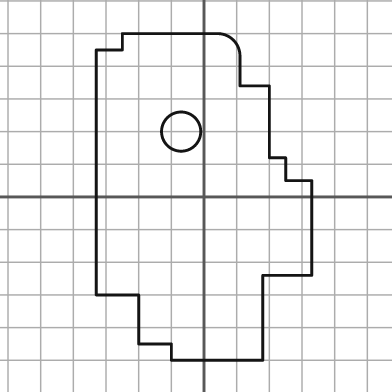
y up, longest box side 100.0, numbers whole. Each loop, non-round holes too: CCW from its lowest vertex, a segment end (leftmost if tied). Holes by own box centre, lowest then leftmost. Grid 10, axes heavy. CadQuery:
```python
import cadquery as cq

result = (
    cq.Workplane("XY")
    .moveTo(-10.0, -50.0)
    .lineTo(18.0, -50.0)
    .lineTo(18.0, -24.0)
    .lineTo(33.0, -24.0)
    .lineTo(33.0, 5.0)
    .lineTo(25.0, 5.0)
    .lineTo(25.0, 12.0)
    .lineTo(20.0, 12.0)
    .lineTo(20.0, 34.0)
    .lineTo(11.0, 34.0)
    .lineTo(11.0, 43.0)
    .threePointArc((9.0, 48.0), (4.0, 50.0))
    .lineTo(-25.0, 50.0)
    .lineTo(-25.0, 45.0)
    .lineTo(-33.0, 45.0)
    .lineTo(-33.0, -30.0)
    .lineTo(-20.0, -30.0)
    .lineTo(-20.0, -45.0)
    .lineTo(-10.0, -45.0)
    .close()
    .moveTo(-7.0, 20.0)
    .circle(6.0)
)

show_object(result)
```